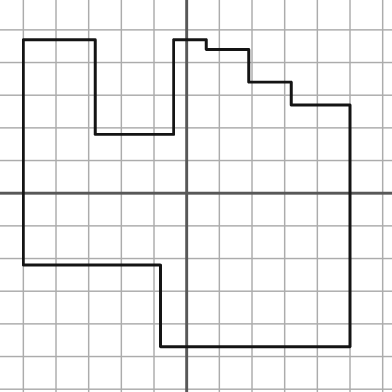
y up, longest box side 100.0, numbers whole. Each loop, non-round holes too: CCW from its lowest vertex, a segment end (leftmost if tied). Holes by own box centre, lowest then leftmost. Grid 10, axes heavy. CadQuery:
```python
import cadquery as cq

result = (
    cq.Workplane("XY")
    .moveTo(-8.0, -47.0)
    .lineTo(50.0, -47.0)
    .lineTo(50.0, 27.0)
    .lineTo(32.0, 27.0)
    .lineTo(32.0, 34.0)
    .lineTo(19.0, 34.0)
    .lineTo(19.0, 44.0)
    .lineTo(6.0, 44.0)
    .lineTo(6.0, 47.0)
    .lineTo(-4.0, 47.0)
    .lineTo(-4.0, 18.0)
    .lineTo(-28.0, 18.0)
    .lineTo(-28.0, 47.0)
    .lineTo(-50.0, 47.0)
    .lineTo(-50.0, -22.0)
    .lineTo(-8.0, -22.0)
    .close()
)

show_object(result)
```